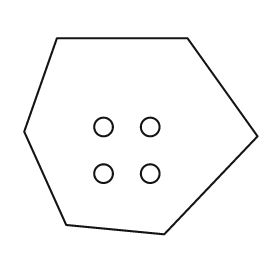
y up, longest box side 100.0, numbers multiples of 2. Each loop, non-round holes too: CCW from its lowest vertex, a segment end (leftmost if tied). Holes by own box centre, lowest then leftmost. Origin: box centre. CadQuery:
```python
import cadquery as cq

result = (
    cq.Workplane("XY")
    .moveTo(10.0, -42.0)
    .lineTo(50.0, 0.0)
    .lineTo(20.0, 42.0)
    .lineTo(-36.0, 42.0)
    .lineTo(-50.0, 2.0)
    .lineTo(-32.0, -38.0)
    .close()
    .moveTo(-16.0, -16.0)
    .circle(4.0)
    .moveTo(4.0, -16.0)
    .circle(4.0)
    .moveTo(-16.0, 4.0)
    .circle(4.0)
    .moveTo(4.0, 4.0)
    .circle(4.0)
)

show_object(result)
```